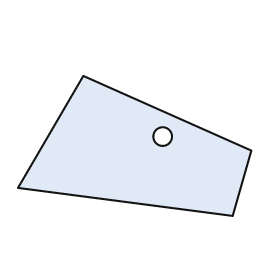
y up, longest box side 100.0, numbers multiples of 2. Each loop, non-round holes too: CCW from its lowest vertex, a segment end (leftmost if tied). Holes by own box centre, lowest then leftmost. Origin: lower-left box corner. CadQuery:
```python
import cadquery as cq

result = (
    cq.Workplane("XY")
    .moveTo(92.0, 0.0)
    .lineTo(100.0, 28.0)
    .lineTo(28.0, 60.0)
    .lineTo(0.0, 12.0)
    .close()
    .moveTo(62.0, 34.0)
    .circle(4.0)
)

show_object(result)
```